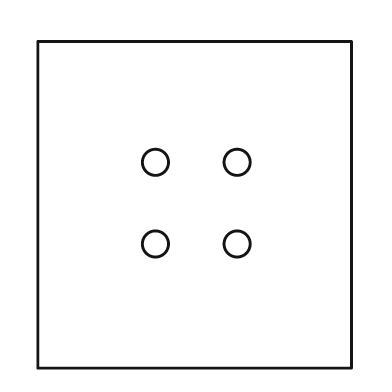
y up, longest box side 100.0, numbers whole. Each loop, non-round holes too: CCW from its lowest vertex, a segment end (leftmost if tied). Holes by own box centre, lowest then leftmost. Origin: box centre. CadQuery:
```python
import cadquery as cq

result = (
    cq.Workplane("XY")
    .moveTo(-48.0, -50.0)
    .lineTo(48.0, -50.0)
    .lineTo(48.0, 50.0)
    .lineTo(-48.0, 50.0)
    .close()
    .moveTo(-12.0, -12.0)
    .circle(4.0)
    .moveTo(13.0, -12.0)
    .circle(4.0)
    .moveTo(-12.0, 13.0)
    .circle(4.0)
    .moveTo(13.0, 13.0)
    .circle(4.0)
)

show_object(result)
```